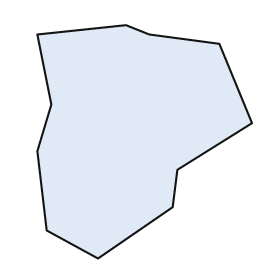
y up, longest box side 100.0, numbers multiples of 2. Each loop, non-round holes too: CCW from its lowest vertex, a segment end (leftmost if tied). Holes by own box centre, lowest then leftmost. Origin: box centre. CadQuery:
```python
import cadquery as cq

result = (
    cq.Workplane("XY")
    .moveTo(-20.0, -50.0)
    .lineTo(12.0, -28.0)
    .lineTo(14.0, -12.0)
    .lineTo(46.0, 8.0)
    .lineTo(32.0, 42.0)
    .lineTo(2.0, 46.0)
    .lineTo(-8.0, 50.0)
    .lineTo(-46.0, 46.0)
    .lineTo(-40.0, 16.0)
    .lineTo(-46.0, -4.0)
    .lineTo(-42.0, -38.0)
    .close()
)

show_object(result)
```